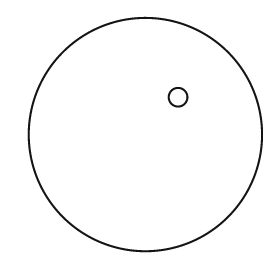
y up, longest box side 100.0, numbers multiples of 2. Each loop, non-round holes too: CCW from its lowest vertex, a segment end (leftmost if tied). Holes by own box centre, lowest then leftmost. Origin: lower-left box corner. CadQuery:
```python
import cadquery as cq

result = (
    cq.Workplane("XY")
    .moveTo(50.0, 50.0)
    .circle(50.0)
    .moveTo(64.0, 66.0)
    .circle(4.0)
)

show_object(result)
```